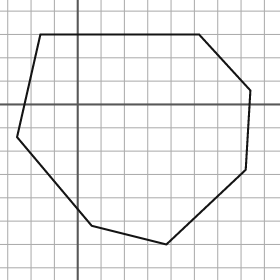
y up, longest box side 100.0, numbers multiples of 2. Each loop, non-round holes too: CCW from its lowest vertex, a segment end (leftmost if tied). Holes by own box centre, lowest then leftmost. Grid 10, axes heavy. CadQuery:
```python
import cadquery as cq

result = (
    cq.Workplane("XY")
    .moveTo(38.0, -60.0)
    .lineTo(72.0, -28.0)
    .lineTo(74.0, 6.0)
    .lineTo(52.0, 30.0)
    .lineTo(-16.0, 30.0)
    .lineTo(-26.0, -14.0)
    .lineTo(6.0, -52.0)
    .close()
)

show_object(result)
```